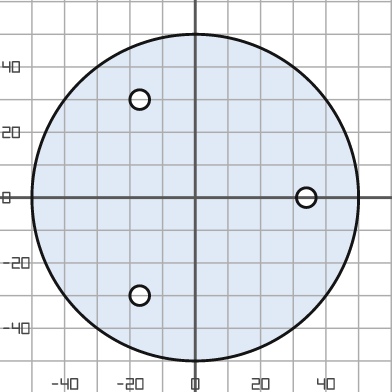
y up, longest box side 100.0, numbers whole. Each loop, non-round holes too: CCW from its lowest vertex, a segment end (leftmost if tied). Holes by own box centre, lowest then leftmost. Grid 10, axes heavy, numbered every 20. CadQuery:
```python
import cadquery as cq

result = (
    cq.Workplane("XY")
    .moveTo(0.0, 0.0)
    .circle(50.0)
    .moveTo(-17.0, -30.0)
    .circle(3.0)
    .moveTo(34.0, 0.0)
    .circle(3.0)
    .moveTo(-17.0, 30.0)
    .circle(3.0)
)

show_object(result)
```